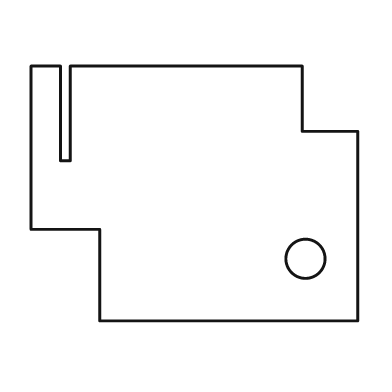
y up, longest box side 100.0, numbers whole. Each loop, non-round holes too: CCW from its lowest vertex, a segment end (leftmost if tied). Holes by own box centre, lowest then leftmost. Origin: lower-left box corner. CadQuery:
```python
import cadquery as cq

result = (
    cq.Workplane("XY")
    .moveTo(21.0, 0.0)
    .lineTo(100.0, 0.0)
    .lineTo(100.0, 58.0)
    .lineTo(83.0, 58.0)
    .lineTo(83.0, 78.0)
    .lineTo(12.0, 78.0)
    .lineTo(12.0, 49.0)
    .lineTo(9.0, 49.0)
    .lineTo(9.0, 78.0)
    .lineTo(0.0, 78.0)
    .lineTo(0.0, 28.0)
    .lineTo(21.0, 28.0)
    .close()
    .moveTo(84.0, 19.0)
    .circle(6.0)
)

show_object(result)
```